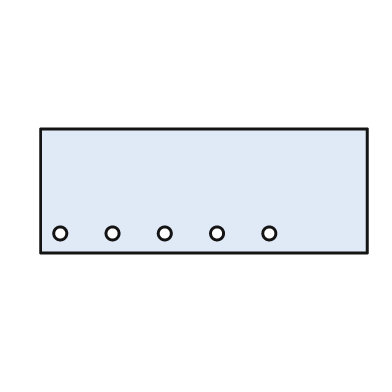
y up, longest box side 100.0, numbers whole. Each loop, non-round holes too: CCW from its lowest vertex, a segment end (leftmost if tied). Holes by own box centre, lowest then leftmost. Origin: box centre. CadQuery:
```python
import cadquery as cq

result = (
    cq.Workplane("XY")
    .moveTo(-50.0, -19.0)
    .lineTo(50.0, -19.0)
    .lineTo(50.0, 19.0)
    .lineTo(-50.0, 19.0)
    .close()
    .moveTo(-44.0, -13.0)
    .circle(2.0)
    .moveTo(-28.0, -13.0)
    .circle(2.0)
    .moveTo(-12.0, -13.0)
    .circle(2.0)
    .moveTo(4.0, -13.0)
    .circle(2.0)
    .moveTo(20.0, -13.0)
    .circle(2.0)
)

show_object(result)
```